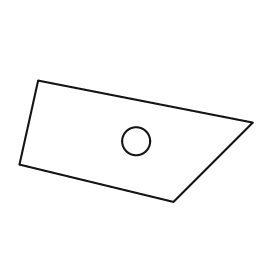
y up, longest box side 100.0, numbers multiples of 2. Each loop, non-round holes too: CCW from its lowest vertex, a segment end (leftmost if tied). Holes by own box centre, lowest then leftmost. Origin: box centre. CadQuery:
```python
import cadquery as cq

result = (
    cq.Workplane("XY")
    .moveTo(16.0, -26.0)
    .lineTo(50.0, 8.0)
    .lineTo(-42.0, 26.0)
    .lineTo(-50.0, -10.0)
    .close()
    .moveTo(0.0, 0.0)
    .circle(6.0)
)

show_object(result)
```